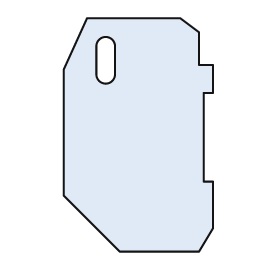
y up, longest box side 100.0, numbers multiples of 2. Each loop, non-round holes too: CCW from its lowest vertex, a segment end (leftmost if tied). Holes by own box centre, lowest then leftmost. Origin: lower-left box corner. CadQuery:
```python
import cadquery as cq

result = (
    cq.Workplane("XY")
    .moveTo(24.0, 0.0)
    .lineTo(58.0, 0.0)
    .lineTo(64.0, 10.0)
    .lineTo(64.0, 30.0)
    .lineTo(60.0, 30.0)
    .lineTo(60.0, 68.0)
    .lineTo(64.0, 68.0)
    .lineTo(64.0, 80.0)
    .lineTo(58.0, 80.0)
    .lineTo(58.0, 94.0)
    .lineTo(50.0, 100.0)
    .lineTo(10.0, 100.0)
    .lineTo(0.0, 78.0)
    .lineTo(0.0, 24.0)
    .close()
    .moveTo(14.0, 76.0)
    .threePointArc((18.0, 72.0), (22.0, 76.0))
    .lineTo(22.0, 88.0)
    .threePointArc((18.0, 92.0), (14.0, 88.0))
    .close()
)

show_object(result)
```